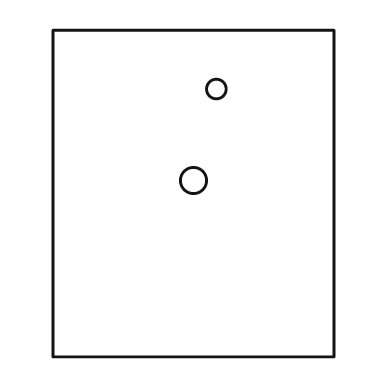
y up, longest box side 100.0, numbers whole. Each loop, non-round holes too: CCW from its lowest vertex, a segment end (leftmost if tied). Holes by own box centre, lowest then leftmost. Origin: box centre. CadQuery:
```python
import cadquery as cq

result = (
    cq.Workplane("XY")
    .moveTo(-43.0, -50.0)
    .lineTo(43.0, -50.0)
    .lineTo(43.0, 50.0)
    .lineTo(-43.0, 50.0)
    .close()
    .moveTo(0.0, 4.0)
    .circle(4.0)
    .moveTo(7.0, 32.0)
    .circle(3.0)
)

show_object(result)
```